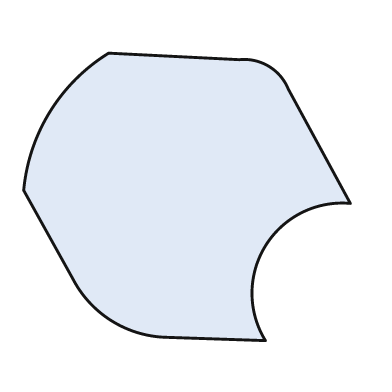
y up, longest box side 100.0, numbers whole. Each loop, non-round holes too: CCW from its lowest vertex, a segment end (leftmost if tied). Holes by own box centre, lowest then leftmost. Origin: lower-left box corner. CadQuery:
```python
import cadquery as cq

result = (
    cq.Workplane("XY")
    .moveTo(74.0, 0.0)
    .threePointArc((74.0, 29.0), (100.0, 42.0))
    .lineTo(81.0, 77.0)
    .threePointArc((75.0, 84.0), (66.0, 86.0))
    .lineTo(26.0, 88.0)
    .threePointArc((8.0, 70.0), (0.0, 46.0))
    .lineTo(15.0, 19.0)
    .threePointArc((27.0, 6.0), (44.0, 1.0))
    .close()
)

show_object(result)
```